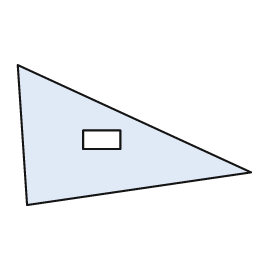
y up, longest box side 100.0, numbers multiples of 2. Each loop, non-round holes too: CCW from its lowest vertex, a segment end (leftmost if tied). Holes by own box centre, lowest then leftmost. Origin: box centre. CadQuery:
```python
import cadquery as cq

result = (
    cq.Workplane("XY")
    .moveTo(-46.0, -30.0)
    .lineTo(50.0, -16.0)
    .lineTo(-50.0, 30.0)
    .close()
    .moveTo(-22.0, -6.0)
    .lineTo(-6.0, -6.0)
    .lineTo(-6.0, 2.0)
    .lineTo(-22.0, 2.0)
    .close()
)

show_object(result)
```